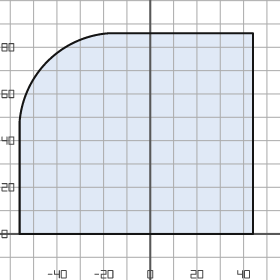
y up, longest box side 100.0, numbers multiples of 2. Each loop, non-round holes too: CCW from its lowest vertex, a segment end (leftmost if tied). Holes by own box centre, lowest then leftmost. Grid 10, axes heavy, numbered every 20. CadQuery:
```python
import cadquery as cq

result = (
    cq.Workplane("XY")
    .moveTo(-56.0, 0.0)
    .lineTo(44.0, 0.0)
    .lineTo(44.0, 86.0)
    .lineTo(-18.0, 86.0)
    .threePointArc((-44.0, 74.0), (-56.0, 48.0))
    .close()
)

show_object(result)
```